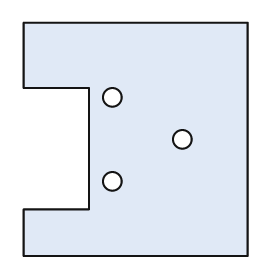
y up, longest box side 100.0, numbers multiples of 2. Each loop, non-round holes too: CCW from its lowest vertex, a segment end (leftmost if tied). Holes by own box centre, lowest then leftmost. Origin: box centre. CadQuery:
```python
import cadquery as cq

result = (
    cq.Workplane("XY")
    .moveTo(-48.0, -50.0)
    .lineTo(48.0, -50.0)
    .lineTo(48.0, 50.0)
    .lineTo(-48.0, 50.0)
    .lineTo(-48.0, 22.0)
    .lineTo(-20.0, 22.0)
    .lineTo(-20.0, -30.0)
    .lineTo(-48.0, -30.0)
    .close()
    .moveTo(-10.0, -18.0)
    .circle(4.0)
    .moveTo(20.0, 0.0)
    .circle(4.0)
    .moveTo(-10.0, 18.0)
    .circle(4.0)
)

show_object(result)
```